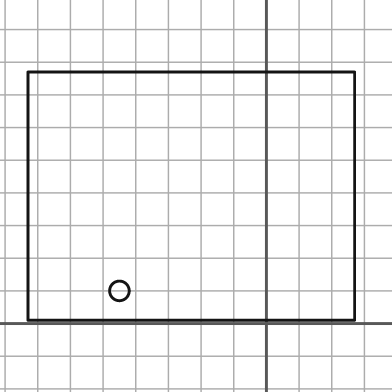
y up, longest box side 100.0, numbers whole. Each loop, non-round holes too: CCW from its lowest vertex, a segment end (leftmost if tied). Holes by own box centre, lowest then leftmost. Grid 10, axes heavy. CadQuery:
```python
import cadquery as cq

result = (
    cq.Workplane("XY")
    .moveTo(-73.0, 1.0)
    .lineTo(27.0, 1.0)
    .lineTo(27.0, 77.0)
    .lineTo(-73.0, 77.0)
    .close()
    .moveTo(-45.0, 10.0)
    .circle(3.0)
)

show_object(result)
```